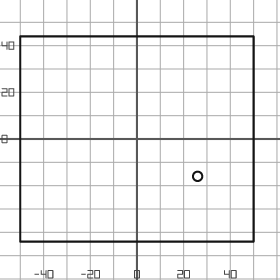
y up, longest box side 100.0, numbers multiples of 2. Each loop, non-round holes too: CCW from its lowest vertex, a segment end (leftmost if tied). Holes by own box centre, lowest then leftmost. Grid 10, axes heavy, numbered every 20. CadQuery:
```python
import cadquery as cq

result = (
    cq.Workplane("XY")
    .moveTo(-50.0, -44.0)
    .lineTo(50.0, -44.0)
    .lineTo(50.0, 44.0)
    .lineTo(-50.0, 44.0)
    .close()
    .moveTo(26.0, -16.0)
    .circle(2.0)
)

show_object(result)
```